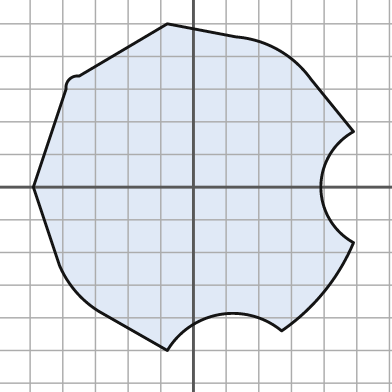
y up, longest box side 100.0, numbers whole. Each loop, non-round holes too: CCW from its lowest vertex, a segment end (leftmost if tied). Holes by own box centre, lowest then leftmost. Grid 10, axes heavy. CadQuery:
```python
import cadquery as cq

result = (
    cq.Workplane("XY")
    .moveTo(-8.0, -50.0)
    .threePointArc((8.0, -39.0), (27.0, -44.0))
    .threePointArc((40.0, -32.0), (49.0, -17.0))
    .threePointArc((39.0, 0.0), (49.0, 17.0))
    .lineTo(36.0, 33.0)
    .threePointArc((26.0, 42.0), (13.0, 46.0))
    .lineTo(-8.0, 50.0)
    .lineTo(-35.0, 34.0)
    .threePointArc((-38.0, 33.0), (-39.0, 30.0))
    .lineTo(-49.0, 0.0)
    .lineTo(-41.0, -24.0)
    .threePointArc((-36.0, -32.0), (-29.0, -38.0))
    .close()
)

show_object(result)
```